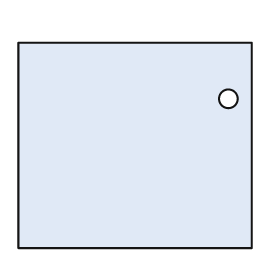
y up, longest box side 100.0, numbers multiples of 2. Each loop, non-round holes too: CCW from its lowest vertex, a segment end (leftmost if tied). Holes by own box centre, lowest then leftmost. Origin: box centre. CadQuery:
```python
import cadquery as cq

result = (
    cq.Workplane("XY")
    .moveTo(-50.0, -44.0)
    .lineTo(50.0, -44.0)
    .lineTo(50.0, 44.0)
    .lineTo(-50.0, 44.0)
    .close()
    .moveTo(40.0, 20.0)
    .circle(4.0)
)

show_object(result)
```